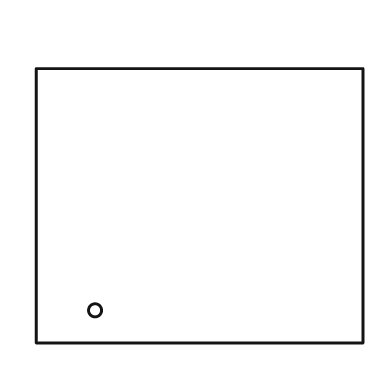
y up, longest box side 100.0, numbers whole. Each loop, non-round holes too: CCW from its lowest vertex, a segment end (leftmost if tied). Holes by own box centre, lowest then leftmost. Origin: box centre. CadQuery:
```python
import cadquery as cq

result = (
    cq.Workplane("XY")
    .moveTo(-50.0, -42.0)
    .lineTo(50.0, -42.0)
    .lineTo(50.0, 42.0)
    .lineTo(-50.0, 42.0)
    .close()
    .moveTo(-32.0, -32.0)
    .circle(2.0)
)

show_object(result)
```